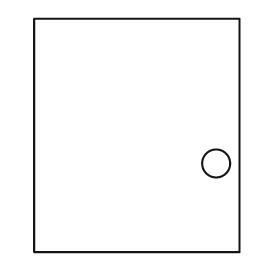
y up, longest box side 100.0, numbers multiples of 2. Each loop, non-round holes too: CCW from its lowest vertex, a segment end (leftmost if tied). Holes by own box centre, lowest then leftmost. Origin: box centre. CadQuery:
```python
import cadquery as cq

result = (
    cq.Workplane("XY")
    .moveTo(-44.0, -50.0)
    .lineTo(44.0, -50.0)
    .lineTo(44.0, 50.0)
    .lineTo(-44.0, 50.0)
    .close()
    .moveTo(34.0, -12.0)
    .circle(6.0)
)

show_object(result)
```